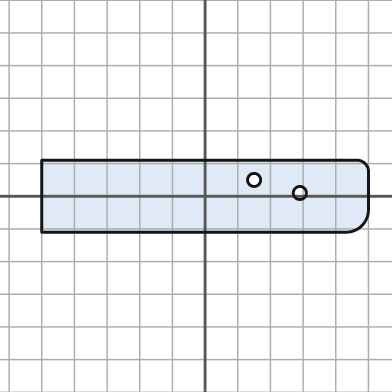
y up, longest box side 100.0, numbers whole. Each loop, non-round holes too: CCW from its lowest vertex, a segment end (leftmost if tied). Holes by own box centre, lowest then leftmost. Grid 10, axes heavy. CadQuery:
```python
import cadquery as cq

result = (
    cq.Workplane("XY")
    .moveTo(-50.0, -11.0)
    .lineTo(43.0, -11.0)
    .threePointArc((48.0, -9.0), (50.0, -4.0))
    .lineTo(50.0, 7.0)
    .threePointArc((49.0, 10.0), (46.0, 11.0))
    .lineTo(-50.0, 11.0)
    .close()
    .moveTo(29.0, 1.0)
    .circle(2.0)
    .moveTo(15.0, 5.0)
    .circle(2.0)
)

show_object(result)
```